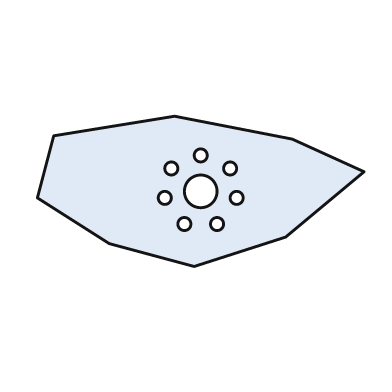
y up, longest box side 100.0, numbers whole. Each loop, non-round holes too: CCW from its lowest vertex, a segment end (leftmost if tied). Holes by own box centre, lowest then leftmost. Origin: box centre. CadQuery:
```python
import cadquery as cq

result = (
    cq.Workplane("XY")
    .moveTo(-2.0, -23.0)
    .lineTo(26.0, -14.0)
    .lineTo(50.0, 6.0)
    .lineTo(28.0, 16.0)
    .lineTo(-8.0, 23.0)
    .lineTo(-45.0, 17.0)
    .lineTo(-50.0, -2.0)
    .lineTo(-28.0, -16.0)
    .close()
    .moveTo(-5.0, -10.0)
    .circle(2.0)
    .moveTo(5.0, -10.0)
    .circle(2.0)
    .moveTo(-11.0, -2.0)
    .circle(2.0)
    .moveTo(11.0, -2.0)
    .circle(2.0)
    .moveTo(0.0, 0.0)
    .circle(5.0)
    .moveTo(-9.0, 7.0)
    .circle(2.0)
    .moveTo(9.0, 7.0)
    .circle(2.0)
    .moveTo(0.0, 11.0)
    .circle(2.0)
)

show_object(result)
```